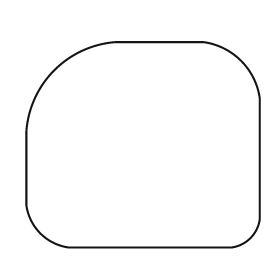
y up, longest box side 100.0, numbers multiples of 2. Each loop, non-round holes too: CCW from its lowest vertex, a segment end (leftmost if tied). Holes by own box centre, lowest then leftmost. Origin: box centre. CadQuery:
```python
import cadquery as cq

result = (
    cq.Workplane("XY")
    .moveTo(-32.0, -44.0)
    .lineTo(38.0, -44.0)
    .threePointArc((46.0, -40.0), (50.0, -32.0))
    .lineTo(50.0, 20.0)
    .threePointArc((42.0, 36.0), (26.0, 44.0))
    .lineTo(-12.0, 44.0)
    .threePointArc((-38.0, 32.0), (-50.0, 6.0))
    .lineTo(-50.0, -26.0)
    .threePointArc((-44.0, -38.0), (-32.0, -44.0))
    .close()
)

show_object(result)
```